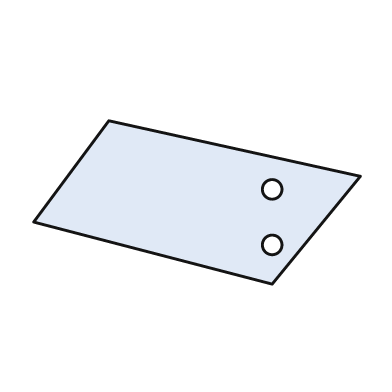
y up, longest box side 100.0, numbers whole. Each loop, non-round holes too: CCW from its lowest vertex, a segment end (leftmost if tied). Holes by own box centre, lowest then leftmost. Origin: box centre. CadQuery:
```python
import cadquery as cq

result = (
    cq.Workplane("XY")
    .moveTo(23.0, -25.0)
    .lineTo(50.0, 8.0)
    .lineTo(-27.0, 25.0)
    .lineTo(-50.0, -6.0)
    .close()
    .moveTo(23.0, -13.0)
    .circle(3.0)
    .moveTo(23.0, 4.0)
    .circle(3.0)
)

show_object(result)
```